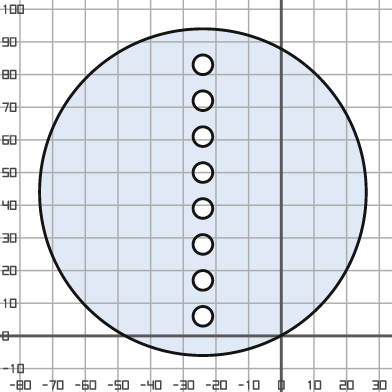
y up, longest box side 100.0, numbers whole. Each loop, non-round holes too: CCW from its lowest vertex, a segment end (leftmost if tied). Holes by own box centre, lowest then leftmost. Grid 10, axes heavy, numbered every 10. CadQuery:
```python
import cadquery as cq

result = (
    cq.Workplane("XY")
    .moveTo(-24.0, 44.0)
    .circle(50.0)
    .moveTo(-24.0, 6.0)
    .circle(3.0)
    .moveTo(-24.0, 17.0)
    .circle(3.0)
    .moveTo(-24.0, 28.0)
    .circle(3.0)
    .moveTo(-24.0, 39.0)
    .circle(3.0)
    .moveTo(-24.0, 50.0)
    .circle(3.0)
    .moveTo(-24.0, 61.0)
    .circle(3.0)
    .moveTo(-24.0, 72.0)
    .circle(3.0)
    .moveTo(-24.0, 83.0)
    .circle(3.0)
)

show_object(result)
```